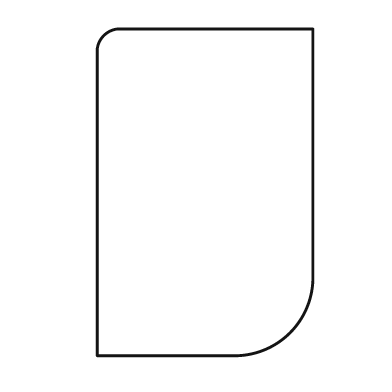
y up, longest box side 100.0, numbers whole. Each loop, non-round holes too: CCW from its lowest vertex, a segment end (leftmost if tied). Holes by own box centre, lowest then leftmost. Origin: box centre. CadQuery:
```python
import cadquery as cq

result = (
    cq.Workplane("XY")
    .moveTo(-33.0, -50.0)
    .lineTo(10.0, -50.0)
    .threePointArc((26.0, -43.0), (33.0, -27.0))
    .lineTo(33.0, 50.0)
    .lineTo(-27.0, 50.0)
    .threePointArc((-31.0, 48.0), (-33.0, 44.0))
    .close()
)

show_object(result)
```